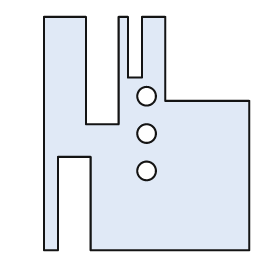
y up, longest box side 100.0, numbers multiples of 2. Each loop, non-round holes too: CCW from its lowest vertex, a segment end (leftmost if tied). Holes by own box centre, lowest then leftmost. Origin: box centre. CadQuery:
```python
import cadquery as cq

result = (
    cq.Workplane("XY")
    .moveTo(-44.0, -50.0)
    .lineTo(-38.0, -50.0)
    .lineTo(-38.0, -10.0)
    .lineTo(-24.0, -10.0)
    .lineTo(-24.0, -50.0)
    .lineTo(44.0, -50.0)
    .lineTo(44.0, 14.0)
    .lineTo(8.0, 14.0)
    .lineTo(8.0, 50.0)
    .lineTo(-2.0, 50.0)
    .lineTo(-2.0, 24.0)
    .lineTo(-8.0, 24.0)
    .lineTo(-8.0, 50.0)
    .lineTo(-12.0, 50.0)
    .lineTo(-12.0, 4.0)
    .lineTo(-26.0, 4.0)
    .lineTo(-26.0, 50.0)
    .lineTo(-44.0, 50.0)
    .close()
    .moveTo(0.0, -16.0)
    .circle(4.0)
    .moveTo(0.0, 0.0)
    .circle(4.0)
    .moveTo(0.0, 16.0)
    .circle(4.0)
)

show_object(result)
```